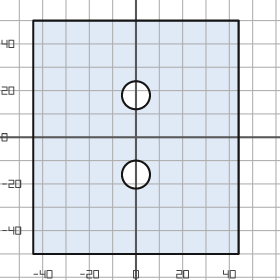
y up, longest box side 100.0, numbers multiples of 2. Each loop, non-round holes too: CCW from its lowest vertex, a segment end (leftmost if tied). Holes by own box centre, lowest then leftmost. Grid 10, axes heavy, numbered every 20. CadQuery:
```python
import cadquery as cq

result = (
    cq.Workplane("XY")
    .moveTo(-44.0, -50.0)
    .lineTo(44.0, -50.0)
    .lineTo(44.0, 50.0)
    .lineTo(-44.0, 50.0)
    .close()
    .moveTo(0.0, -16.0)
    .circle(6.0)
    .moveTo(0.0, 18.0)
    .circle(6.0)
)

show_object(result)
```